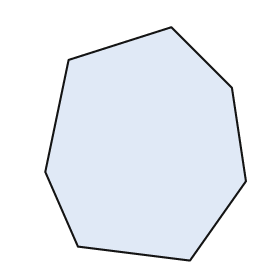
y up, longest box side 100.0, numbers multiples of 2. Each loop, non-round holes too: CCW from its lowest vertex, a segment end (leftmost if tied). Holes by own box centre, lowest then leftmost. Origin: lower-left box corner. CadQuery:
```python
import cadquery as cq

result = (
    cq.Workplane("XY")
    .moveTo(62.0, 0.0)
    .lineTo(86.0, 34.0)
    .lineTo(80.0, 74.0)
    .lineTo(54.0, 100.0)
    .lineTo(10.0, 86.0)
    .lineTo(0.0, 38.0)
    .lineTo(14.0, 6.0)
    .close()
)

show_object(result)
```